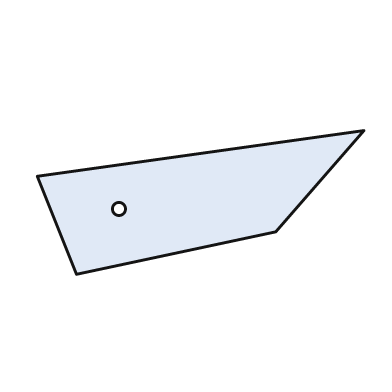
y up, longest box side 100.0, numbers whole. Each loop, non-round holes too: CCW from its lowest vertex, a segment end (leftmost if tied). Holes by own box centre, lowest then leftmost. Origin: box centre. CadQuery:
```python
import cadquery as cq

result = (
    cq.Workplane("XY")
    .moveTo(-38.0, -22.0)
    .lineTo(23.0, -9.0)
    .lineTo(50.0, 22.0)
    .lineTo(-50.0, 8.0)
    .close()
    .moveTo(-25.0, -2.0)
    .circle(2.0)
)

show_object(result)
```